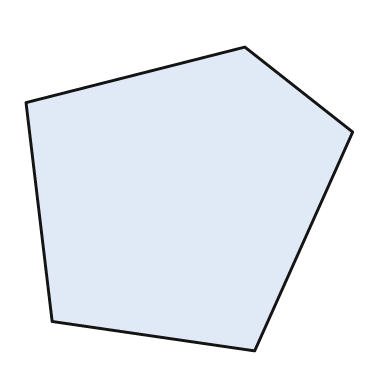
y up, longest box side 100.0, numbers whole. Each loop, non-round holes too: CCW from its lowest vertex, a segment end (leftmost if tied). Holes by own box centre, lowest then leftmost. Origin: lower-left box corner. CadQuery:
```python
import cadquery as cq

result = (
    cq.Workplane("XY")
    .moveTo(70.0, 0.0)
    .lineTo(100.0, 67.0)
    .lineTo(67.0, 93.0)
    .lineTo(0.0, 76.0)
    .lineTo(8.0, 9.0)
    .close()
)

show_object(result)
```